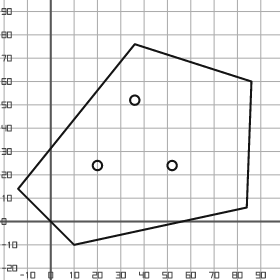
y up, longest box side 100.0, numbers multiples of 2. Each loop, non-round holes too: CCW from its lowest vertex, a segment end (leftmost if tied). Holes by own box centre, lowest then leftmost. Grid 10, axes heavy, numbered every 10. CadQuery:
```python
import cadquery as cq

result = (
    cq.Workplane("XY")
    .moveTo(10.0, -10.0)
    .lineTo(84.0, 6.0)
    .lineTo(86.0, 60.0)
    .lineTo(36.0, 76.0)
    .lineTo(-14.0, 14.0)
    .close()
    .moveTo(20.0, 24.0)
    .circle(2.0)
    .moveTo(52.0, 24.0)
    .circle(2.0)
    .moveTo(36.0, 52.0)
    .circle(2.0)
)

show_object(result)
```